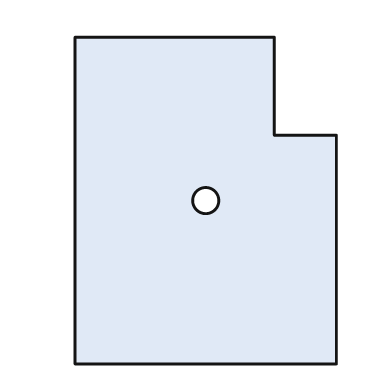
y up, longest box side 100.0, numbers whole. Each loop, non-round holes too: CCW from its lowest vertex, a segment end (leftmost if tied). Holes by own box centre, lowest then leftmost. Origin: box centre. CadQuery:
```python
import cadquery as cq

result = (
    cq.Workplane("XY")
    .moveTo(-40.0, -50.0)
    .lineTo(40.0, -50.0)
    .lineTo(40.0, 20.0)
    .lineTo(21.0, 20.0)
    .lineTo(21.0, 50.0)
    .lineTo(-40.0, 50.0)
    .close()
    .moveTo(0.0, 0.0)
    .circle(4.0)
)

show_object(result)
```